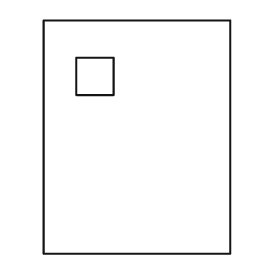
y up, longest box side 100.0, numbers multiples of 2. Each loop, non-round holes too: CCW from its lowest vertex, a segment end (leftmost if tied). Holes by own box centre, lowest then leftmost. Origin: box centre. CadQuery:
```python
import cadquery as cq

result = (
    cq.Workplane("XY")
    .moveTo(-40.0, -50.0)
    .lineTo(40.0, -50.0)
    .lineTo(40.0, 50.0)
    .lineTo(-40.0, 50.0)
    .close()
    .moveTo(-26.0, 18.0)
    .lineTo(-10.0, 18.0)
    .lineTo(-10.0, 34.0)
    .lineTo(-26.0, 34.0)
    .close()
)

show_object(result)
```